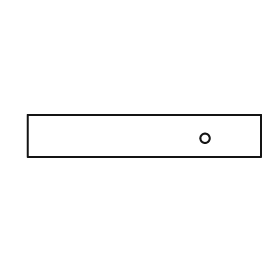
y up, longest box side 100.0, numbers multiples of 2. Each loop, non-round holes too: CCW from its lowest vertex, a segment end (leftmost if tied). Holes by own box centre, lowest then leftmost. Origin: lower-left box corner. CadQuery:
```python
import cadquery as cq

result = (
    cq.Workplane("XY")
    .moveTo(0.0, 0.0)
    .lineTo(100.0, 0.0)
    .lineTo(100.0, 18.0)
    .lineTo(0.0, 18.0)
    .close()
    .moveTo(76.0, 8.0)
    .circle(2.0)
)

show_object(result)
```